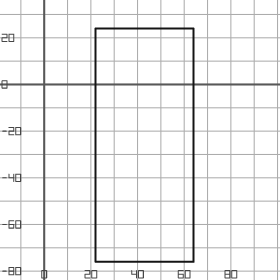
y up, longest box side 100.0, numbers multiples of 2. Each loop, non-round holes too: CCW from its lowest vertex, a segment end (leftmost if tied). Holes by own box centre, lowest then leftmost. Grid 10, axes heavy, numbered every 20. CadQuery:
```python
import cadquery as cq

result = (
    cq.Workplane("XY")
    .moveTo(22.0, -76.0)
    .lineTo(64.0, -76.0)
    .lineTo(64.0, 24.0)
    .lineTo(22.0, 24.0)
    .close()
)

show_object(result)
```